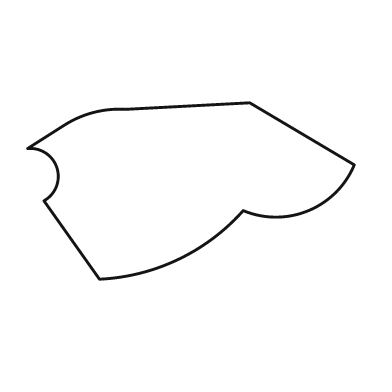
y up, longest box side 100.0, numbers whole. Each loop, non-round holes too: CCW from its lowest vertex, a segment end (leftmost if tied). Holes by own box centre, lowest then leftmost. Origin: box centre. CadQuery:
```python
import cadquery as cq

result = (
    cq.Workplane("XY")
    .moveTo(-28.0, -27.0)
    .threePointArc((-4.0, -21.0), (16.0, -6.0))
    .threePointArc((36.0, -6.0), (50.0, 8.0))
    .lineTo(18.0, 27.0)
    .lineTo(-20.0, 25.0)
    .threePointArc((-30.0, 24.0), (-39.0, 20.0))
    .lineTo(-50.0, 13.0)
    .threePointArc((-41.0, 7.0), (-45.0, -3.0))
    .close()
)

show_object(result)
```